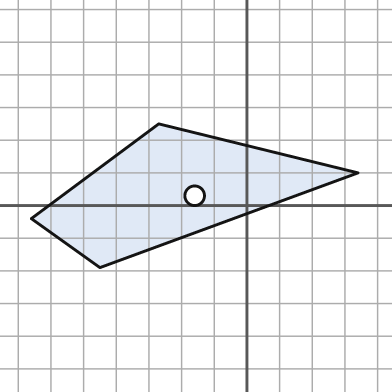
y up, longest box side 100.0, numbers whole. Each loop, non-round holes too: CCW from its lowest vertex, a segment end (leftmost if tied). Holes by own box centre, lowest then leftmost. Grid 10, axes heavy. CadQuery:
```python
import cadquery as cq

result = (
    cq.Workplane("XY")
    .moveTo(-45.0, -19.0)
    .lineTo(34.0, 10.0)
    .lineTo(-27.0, 25.0)
    .lineTo(-66.0, -4.0)
    .close()
    .moveTo(-16.0, 3.0)
    .circle(3.0)
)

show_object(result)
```